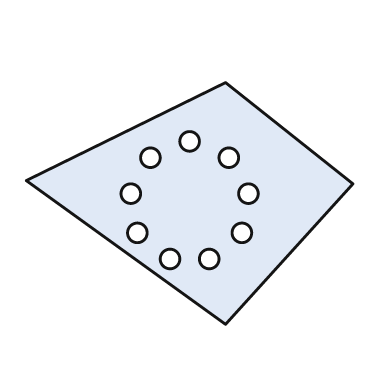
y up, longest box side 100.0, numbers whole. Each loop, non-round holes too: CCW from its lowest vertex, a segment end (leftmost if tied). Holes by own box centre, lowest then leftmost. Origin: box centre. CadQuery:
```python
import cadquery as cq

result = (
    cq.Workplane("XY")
    .moveTo(11.0, -37.0)
    .lineTo(50.0, 6.0)
    .lineTo(11.0, 37.0)
    .lineTo(-50.0, 7.0)
    .close()
    .moveTo(-6.0, -17.0)
    .circle(3.0)
    .moveTo(6.0, -17.0)
    .circle(3.0)
    .moveTo(-16.0, -9.0)
    .circle(3.0)
    .moveTo(16.0, -9.0)
    .circle(3.0)
    .moveTo(-18.0, 3.0)
    .circle(3.0)
    .moveTo(18.0, 3.0)
    .circle(3.0)
    .moveTo(-12.0, 14.0)
    .circle(3.0)
    .moveTo(12.0, 14.0)
    .circle(3.0)
    .moveTo(0.0, 19.0)
    .circle(3.0)
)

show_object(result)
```